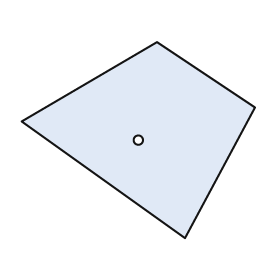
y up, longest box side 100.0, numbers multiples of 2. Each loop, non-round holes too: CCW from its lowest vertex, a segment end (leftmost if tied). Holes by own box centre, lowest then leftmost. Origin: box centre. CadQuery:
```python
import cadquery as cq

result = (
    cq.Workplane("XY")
    .moveTo(20.0, -42.0)
    .lineTo(50.0, 14.0)
    .lineTo(8.0, 42.0)
    .lineTo(-50.0, 8.0)
    .close()
    .moveTo(0.0, 0.0)
    .circle(2.0)
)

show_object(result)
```